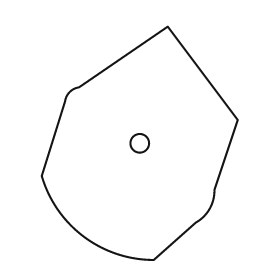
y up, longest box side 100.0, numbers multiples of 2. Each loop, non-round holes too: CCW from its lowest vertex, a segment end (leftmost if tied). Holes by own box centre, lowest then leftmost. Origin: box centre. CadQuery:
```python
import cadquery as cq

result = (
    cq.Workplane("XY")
    .moveTo(6.0, -50.0)
    .lineTo(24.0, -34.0)
    .threePointArc((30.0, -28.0), (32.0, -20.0))
    .lineTo(42.0, 10.0)
    .lineTo(12.0, 50.0)
    .lineTo(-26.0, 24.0)
    .threePointArc((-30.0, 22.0), (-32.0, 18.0))
    .lineTo(-42.0, -14.0)
    .threePointArc((-24.0, -40.0), (6.0, -50.0))
    .close()
    .moveTo(0.0, 0.0)
    .circle(4.0)
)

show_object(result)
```